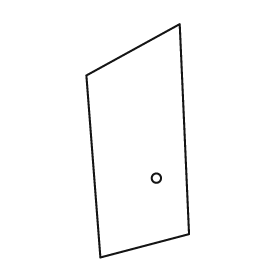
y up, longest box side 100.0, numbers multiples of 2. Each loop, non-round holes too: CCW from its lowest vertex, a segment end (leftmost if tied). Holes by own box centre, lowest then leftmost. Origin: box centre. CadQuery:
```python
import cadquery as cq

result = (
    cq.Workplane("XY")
    .moveTo(-16.0, -50.0)
    .lineTo(22.0, -40.0)
    .lineTo(18.0, 50.0)
    .lineTo(-22.0, 28.0)
    .close()
    .moveTo(8.0, -16.0)
    .circle(2.0)
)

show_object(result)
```